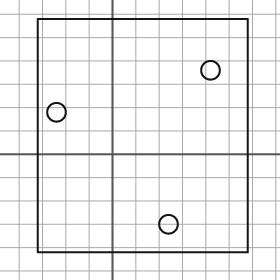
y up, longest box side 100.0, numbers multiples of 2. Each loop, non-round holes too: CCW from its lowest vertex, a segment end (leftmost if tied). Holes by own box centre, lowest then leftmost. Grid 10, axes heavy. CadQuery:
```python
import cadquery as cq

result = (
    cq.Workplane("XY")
    .moveTo(-32.0, -42.0)
    .lineTo(58.0, -42.0)
    .lineTo(58.0, 58.0)
    .lineTo(-32.0, 58.0)
    .close()
    .moveTo(24.0, -30.0)
    .circle(4.0)
    .moveTo(-24.0, 18.0)
    .circle(4.0)
    .moveTo(42.0, 36.0)
    .circle(4.0)
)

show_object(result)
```